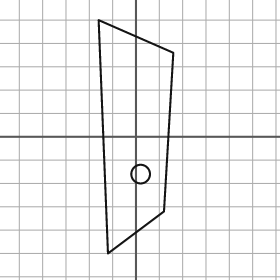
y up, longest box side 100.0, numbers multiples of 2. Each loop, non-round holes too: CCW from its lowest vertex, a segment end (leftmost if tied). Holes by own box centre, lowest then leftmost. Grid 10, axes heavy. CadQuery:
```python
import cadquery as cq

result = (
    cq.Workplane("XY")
    .moveTo(-12.0, -50.0)
    .lineTo(12.0, -32.0)
    .lineTo(16.0, 36.0)
    .lineTo(-16.0, 50.0)
    .close()
    .moveTo(2.0, -16.0)
    .circle(4.0)
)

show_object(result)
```